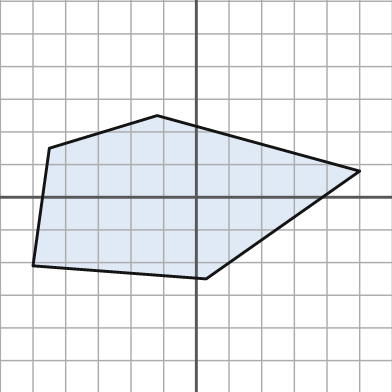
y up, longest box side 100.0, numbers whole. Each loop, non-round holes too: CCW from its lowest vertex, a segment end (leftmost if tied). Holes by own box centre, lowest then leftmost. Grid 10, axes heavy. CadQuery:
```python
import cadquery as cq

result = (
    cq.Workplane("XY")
    .moveTo(3.0, -25.0)
    .lineTo(50.0, 8.0)
    .lineTo(-12.0, 25.0)
    .lineTo(-45.0, 15.0)
    .lineTo(-50.0, -21.0)
    .close()
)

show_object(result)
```